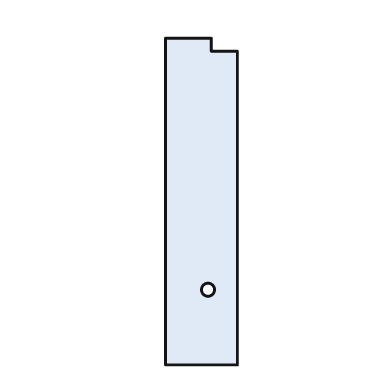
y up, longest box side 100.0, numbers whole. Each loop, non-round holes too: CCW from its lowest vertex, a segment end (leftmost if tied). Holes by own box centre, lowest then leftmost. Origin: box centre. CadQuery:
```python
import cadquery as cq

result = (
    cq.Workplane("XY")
    .moveTo(-11.0, -50.0)
    .lineTo(11.0, -50.0)
    .lineTo(11.0, 46.0)
    .lineTo(3.0, 46.0)
    .lineTo(3.0, 50.0)
    .lineTo(-11.0, 50.0)
    .close()
    .moveTo(2.0, -27.0)
    .circle(2.0)
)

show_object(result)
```